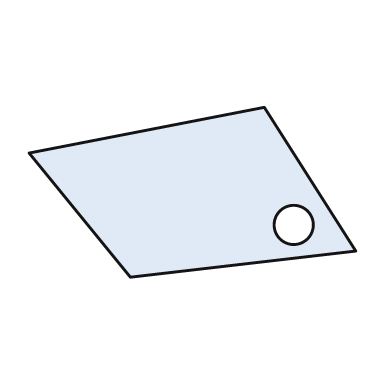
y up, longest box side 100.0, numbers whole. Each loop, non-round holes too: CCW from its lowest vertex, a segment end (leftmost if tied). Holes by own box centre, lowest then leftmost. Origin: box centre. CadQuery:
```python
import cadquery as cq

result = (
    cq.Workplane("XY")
    .moveTo(-19.0, -26.0)
    .lineTo(50.0, -18.0)
    .lineTo(22.0, 26.0)
    .lineTo(-50.0, 12.0)
    .close()
    .moveTo(31.0, -10.0)
    .circle(6.0)
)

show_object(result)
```